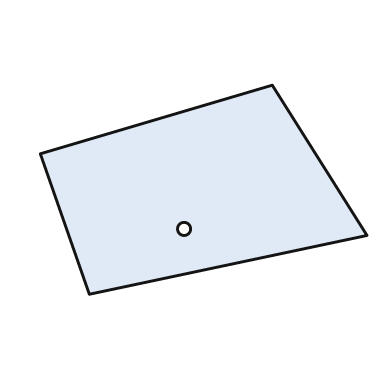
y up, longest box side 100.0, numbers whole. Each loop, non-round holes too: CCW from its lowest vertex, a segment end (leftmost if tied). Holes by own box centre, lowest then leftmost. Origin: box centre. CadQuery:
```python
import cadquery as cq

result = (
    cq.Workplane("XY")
    .moveTo(-35.0, -32.0)
    .lineTo(50.0, -14.0)
    .lineTo(21.0, 32.0)
    .lineTo(-50.0, 11.0)
    .close()
    .moveTo(-6.0, -12.0)
    .circle(2.0)
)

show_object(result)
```